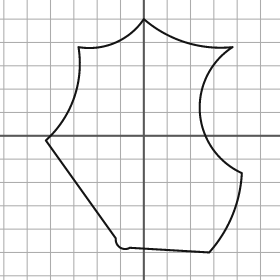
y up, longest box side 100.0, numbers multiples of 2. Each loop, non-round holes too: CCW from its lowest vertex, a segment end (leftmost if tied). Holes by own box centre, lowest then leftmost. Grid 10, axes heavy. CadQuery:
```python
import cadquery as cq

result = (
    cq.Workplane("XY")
    .moveTo(28.0, -50.0)
    .threePointArc((38.0, -34.0), (42.0, -16.0))
    .threePointArc((24.0, 10.0), (38.0, 38.0))
    .threePointArc((18.0, 40.0), (0.0, 50.0))
    .threePointArc((-12.0, 40.0), (-28.0, 38.0))
    .threePointArc((-30.0, 16.0), (-42.0, -2.0))
    .lineTo(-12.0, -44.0)
    .threePointArc((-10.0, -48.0), (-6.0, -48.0))
    .close()
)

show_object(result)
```